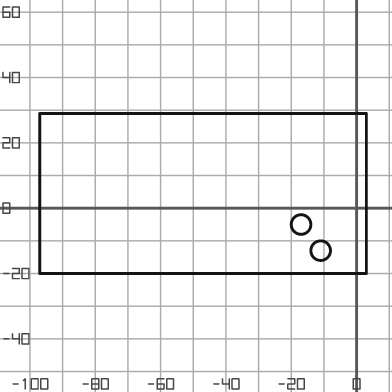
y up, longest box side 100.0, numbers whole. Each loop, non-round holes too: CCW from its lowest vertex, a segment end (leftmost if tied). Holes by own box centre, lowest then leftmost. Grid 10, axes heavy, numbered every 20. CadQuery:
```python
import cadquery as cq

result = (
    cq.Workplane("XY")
    .moveTo(-97.0, -20.0)
    .lineTo(3.0, -20.0)
    .lineTo(3.0, 29.0)
    .lineTo(-97.0, 29.0)
    .close()
    .moveTo(-11.0, -13.0)
    .circle(3.0)
    .moveTo(-17.0, -5.0)
    .circle(3.0)
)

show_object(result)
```